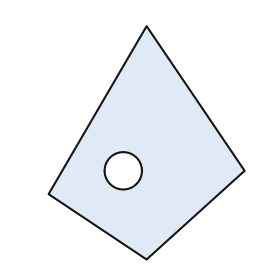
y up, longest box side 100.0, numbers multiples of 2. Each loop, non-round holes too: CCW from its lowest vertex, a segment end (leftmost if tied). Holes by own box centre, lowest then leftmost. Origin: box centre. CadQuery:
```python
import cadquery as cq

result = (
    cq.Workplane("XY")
    .moveTo(0.0, -50.0)
    .lineTo(42.0, -12.0)
    .lineTo(0.0, 50.0)
    .lineTo(-42.0, -22.0)
    .close()
    .moveTo(-10.0, -12.0)
    .circle(8.0)
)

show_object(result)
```